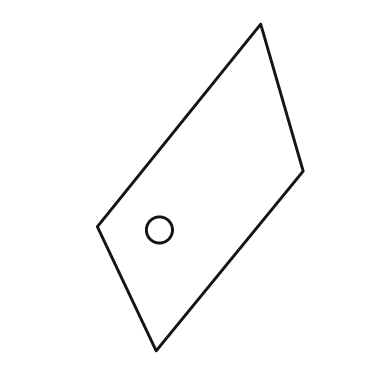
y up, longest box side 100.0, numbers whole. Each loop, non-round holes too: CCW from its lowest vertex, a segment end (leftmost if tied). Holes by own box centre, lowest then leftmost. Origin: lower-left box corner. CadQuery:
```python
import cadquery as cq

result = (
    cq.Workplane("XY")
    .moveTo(18.0, 0.0)
    .lineTo(63.0, 55.0)
    .lineTo(50.0, 100.0)
    .lineTo(0.0, 38.0)
    .close()
    .moveTo(19.0, 37.0)
    .circle(4.0)
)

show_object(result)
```